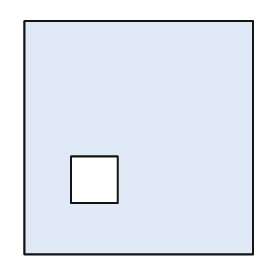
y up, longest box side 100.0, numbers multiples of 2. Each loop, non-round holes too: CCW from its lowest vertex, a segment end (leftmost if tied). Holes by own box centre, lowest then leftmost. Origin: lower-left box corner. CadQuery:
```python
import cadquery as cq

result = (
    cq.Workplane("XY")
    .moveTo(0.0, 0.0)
    .lineTo(98.0, 0.0)
    .lineTo(98.0, 100.0)
    .lineTo(0.0, 100.0)
    .close()
    .moveTo(20.0, 22.0)
    .lineTo(40.0, 22.0)
    .lineTo(40.0, 42.0)
    .lineTo(20.0, 42.0)
    .close()
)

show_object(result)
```